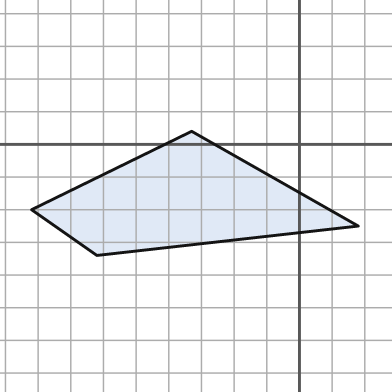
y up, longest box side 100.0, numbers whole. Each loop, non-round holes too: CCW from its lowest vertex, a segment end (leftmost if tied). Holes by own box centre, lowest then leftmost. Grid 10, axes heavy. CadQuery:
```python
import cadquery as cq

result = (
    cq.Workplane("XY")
    .moveTo(-62.0, -34.0)
    .lineTo(18.0, -25.0)
    .lineTo(-33.0, 4.0)
    .lineTo(-82.0, -20.0)
    .close()
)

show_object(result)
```